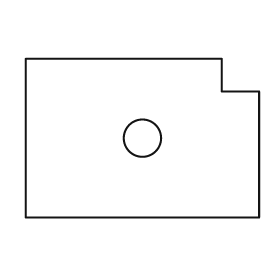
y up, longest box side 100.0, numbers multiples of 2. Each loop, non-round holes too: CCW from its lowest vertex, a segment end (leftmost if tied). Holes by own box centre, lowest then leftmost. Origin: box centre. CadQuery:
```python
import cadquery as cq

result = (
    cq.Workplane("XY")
    .moveTo(-50.0, -34.0)
    .lineTo(50.0, -34.0)
    .lineTo(50.0, 20.0)
    .lineTo(34.0, 20.0)
    .lineTo(34.0, 34.0)
    .lineTo(-50.0, 34.0)
    .close()
    .moveTo(0.0, 0.0)
    .circle(8.0)
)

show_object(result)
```